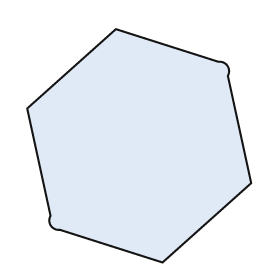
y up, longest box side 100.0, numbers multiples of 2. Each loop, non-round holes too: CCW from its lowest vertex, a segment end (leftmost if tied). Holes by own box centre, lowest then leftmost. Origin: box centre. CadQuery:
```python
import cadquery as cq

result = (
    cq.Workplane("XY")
    .moveTo(10.0, -50.0)
    .lineTo(48.0, -16.0)
    .lineTo(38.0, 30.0)
    .threePointArc((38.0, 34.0), (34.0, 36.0))
    .lineTo(-10.0, 50.0)
    .lineTo(-48.0, 16.0)
    .lineTo(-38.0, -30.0)
    .threePointArc((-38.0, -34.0), (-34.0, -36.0))
    .close()
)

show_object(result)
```